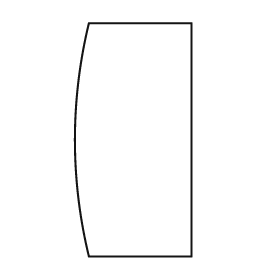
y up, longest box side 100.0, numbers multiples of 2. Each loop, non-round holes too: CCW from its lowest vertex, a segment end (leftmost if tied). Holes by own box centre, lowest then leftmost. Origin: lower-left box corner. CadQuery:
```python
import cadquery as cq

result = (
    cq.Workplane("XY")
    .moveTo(6.0, 0.0)
    .lineTo(50.0, 0.0)
    .lineTo(50.0, 100.0)
    .lineTo(6.0, 100.0)
    .threePointArc((0.0, 50.0), (6.0, 0.0))
    .close()
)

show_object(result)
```